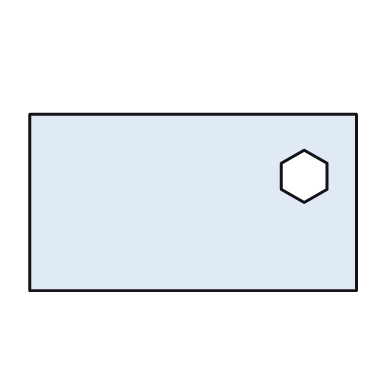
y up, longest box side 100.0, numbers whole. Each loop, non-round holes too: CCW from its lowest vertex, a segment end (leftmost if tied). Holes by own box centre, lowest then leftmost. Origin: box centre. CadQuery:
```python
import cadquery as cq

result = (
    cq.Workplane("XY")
    .moveTo(-50.0, -27.0)
    .lineTo(50.0, -27.0)
    .lineTo(50.0, 27.0)
    .lineTo(-50.0, 27.0)
    .close()
    .moveTo(34.0, 0.0)
    .lineTo(41.0, 4.0)
    .lineTo(41.0, 12.0)
    .lineTo(34.0, 16.0)
    .lineTo(27.0, 12.0)
    .lineTo(27.0, 4.0)
    .close()
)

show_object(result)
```